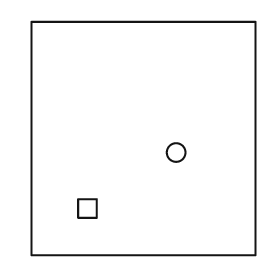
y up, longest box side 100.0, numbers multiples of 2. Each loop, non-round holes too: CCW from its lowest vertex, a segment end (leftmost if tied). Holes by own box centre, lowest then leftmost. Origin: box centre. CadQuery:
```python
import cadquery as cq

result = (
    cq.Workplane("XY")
    .moveTo(-48.0, -50.0)
    .lineTo(48.0, -50.0)
    .lineTo(48.0, 50.0)
    .lineTo(-48.0, 50.0)
    .close()
    .moveTo(-28.0, -34.0)
    .lineTo(-20.0, -34.0)
    .lineTo(-20.0, -26.0)
    .lineTo(-28.0, -26.0)
    .close()
    .moveTo(14.0, -6.0)
    .circle(4.0)
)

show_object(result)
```